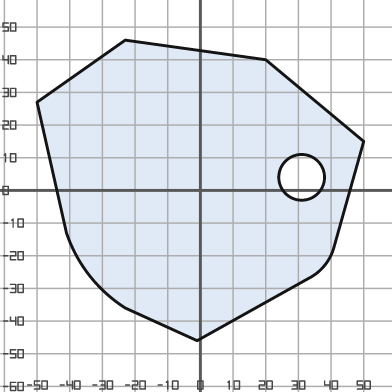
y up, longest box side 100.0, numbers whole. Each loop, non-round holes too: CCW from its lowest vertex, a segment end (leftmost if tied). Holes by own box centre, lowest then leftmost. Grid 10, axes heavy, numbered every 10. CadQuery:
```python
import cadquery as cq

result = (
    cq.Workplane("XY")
    .moveTo(-1.0, -46.0)
    .lineTo(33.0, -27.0)
    .threePointArc((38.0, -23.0), (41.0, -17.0))
    .lineTo(50.0, 15.0)
    .lineTo(20.0, 40.0)
    .lineTo(-23.0, 46.0)
    .lineTo(-50.0, 27.0)
    .lineTo(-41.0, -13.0)
    .threePointArc((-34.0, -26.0), (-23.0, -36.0))
    .close()
    .moveTo(31.0, 4.0)
    .circle(7.0)
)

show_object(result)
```